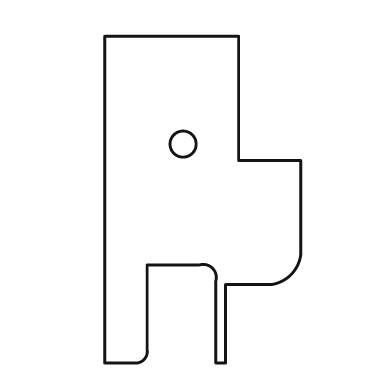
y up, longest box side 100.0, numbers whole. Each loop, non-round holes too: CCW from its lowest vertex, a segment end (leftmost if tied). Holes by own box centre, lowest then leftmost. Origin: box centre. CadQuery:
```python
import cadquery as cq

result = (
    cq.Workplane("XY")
    .moveTo(-30.0, -50.0)
    .lineTo(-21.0, -50.0)
    .threePointArc((-18.0, -49.0), (-17.0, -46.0))
    .lineTo(-17.0, -20.0)
    .lineTo(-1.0, -20.0)
    .threePointArc((3.0, -21.0), (4.0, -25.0))
    .lineTo(4.0, -50.0)
    .lineTo(7.0, -50.0)
    .lineTo(7.0, -26.0)
    .lineTo(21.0, -26.0)
    .threePointArc((27.0, -23.0), (30.0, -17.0))
    .lineTo(30.0, 12.0)
    .lineTo(11.0, 12.0)
    .lineTo(11.0, 50.0)
    .lineTo(-30.0, 50.0)
    .close()
    .moveTo(-6.0, 17.0)
    .circle(4.0)
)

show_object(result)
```